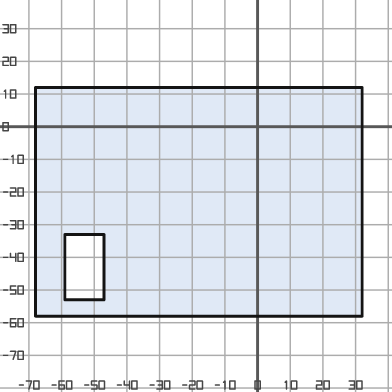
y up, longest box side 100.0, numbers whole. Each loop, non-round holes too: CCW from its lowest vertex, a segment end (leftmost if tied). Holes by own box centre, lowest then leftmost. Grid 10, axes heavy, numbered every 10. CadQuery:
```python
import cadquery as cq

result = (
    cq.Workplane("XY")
    .moveTo(-68.0, -58.0)
    .lineTo(32.0, -58.0)
    .lineTo(32.0, 12.0)
    .lineTo(-68.0, 12.0)
    .close()
    .moveTo(-59.0, -53.0)
    .lineTo(-47.0, -53.0)
    .lineTo(-47.0, -33.0)
    .lineTo(-59.0, -33.0)
    .close()
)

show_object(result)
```